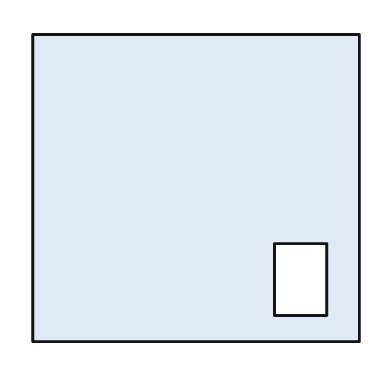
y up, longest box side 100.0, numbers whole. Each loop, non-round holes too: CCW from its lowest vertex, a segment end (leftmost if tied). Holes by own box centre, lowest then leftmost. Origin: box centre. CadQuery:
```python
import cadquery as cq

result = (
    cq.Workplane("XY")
    .moveTo(-50.0, -47.0)
    .lineTo(50.0, -47.0)
    .lineTo(50.0, 47.0)
    .lineTo(-50.0, 47.0)
    .close()
    .moveTo(24.0, -39.0)
    .lineTo(40.0, -39.0)
    .lineTo(40.0, -17.0)
    .lineTo(24.0, -17.0)
    .close()
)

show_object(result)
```